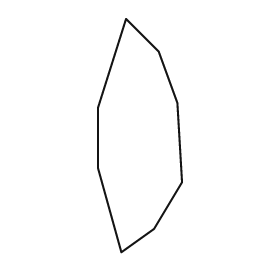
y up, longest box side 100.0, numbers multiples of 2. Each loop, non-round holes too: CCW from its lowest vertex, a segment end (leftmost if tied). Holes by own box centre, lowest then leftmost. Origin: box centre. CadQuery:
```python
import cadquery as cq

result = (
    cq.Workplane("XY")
    .moveTo(-8.0, -50.0)
    .lineTo(6.0, -40.0)
    .lineTo(18.0, -20.0)
    .lineTo(16.0, 14.0)
    .lineTo(8.0, 36.0)
    .lineTo(-6.0, 50.0)
    .lineTo(-18.0, 12.0)
    .lineTo(-18.0, -14.0)
    .close()
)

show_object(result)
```